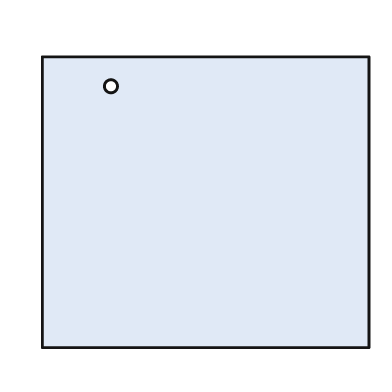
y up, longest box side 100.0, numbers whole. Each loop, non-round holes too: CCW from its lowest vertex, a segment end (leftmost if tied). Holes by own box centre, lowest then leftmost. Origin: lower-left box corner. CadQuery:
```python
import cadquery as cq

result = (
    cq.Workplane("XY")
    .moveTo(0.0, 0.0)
    .lineTo(100.0, 0.0)
    .lineTo(100.0, 89.0)
    .lineTo(0.0, 89.0)
    .close()
    .moveTo(21.0, 80.0)
    .circle(2.0)
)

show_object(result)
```